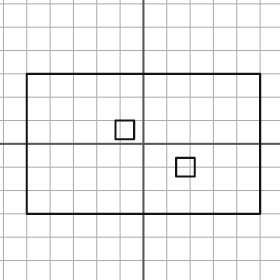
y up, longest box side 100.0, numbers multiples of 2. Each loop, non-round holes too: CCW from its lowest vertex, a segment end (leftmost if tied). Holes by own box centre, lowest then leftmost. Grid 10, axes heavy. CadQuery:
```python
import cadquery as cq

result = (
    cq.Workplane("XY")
    .moveTo(-50.0, -30.0)
    .lineTo(50.0, -30.0)
    .lineTo(50.0, 30.0)
    .lineTo(-50.0, 30.0)
    .close()
    .moveTo(14.0, -14.0)
    .lineTo(22.0, -14.0)
    .lineTo(22.0, -6.0)
    .lineTo(14.0, -6.0)
    .close()
    .moveTo(-12.0, 2.0)
    .lineTo(-4.0, 2.0)
    .lineTo(-4.0, 10.0)
    .lineTo(-12.0, 10.0)
    .close()
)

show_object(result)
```